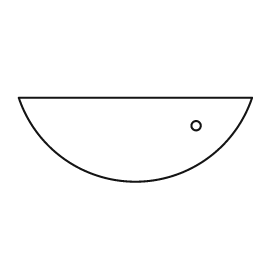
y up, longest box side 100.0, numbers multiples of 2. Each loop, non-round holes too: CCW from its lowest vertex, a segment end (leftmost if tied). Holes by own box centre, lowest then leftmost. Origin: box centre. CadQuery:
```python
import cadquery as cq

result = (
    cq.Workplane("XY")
    .moveTo(-50.0, 18.0)
    .threePointArc((0.0, -18.0), (50.0, 18.0))
    .close()
    .moveTo(26.0, 6.0)
    .circle(2.0)
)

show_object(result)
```